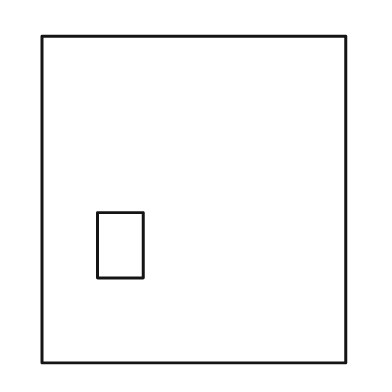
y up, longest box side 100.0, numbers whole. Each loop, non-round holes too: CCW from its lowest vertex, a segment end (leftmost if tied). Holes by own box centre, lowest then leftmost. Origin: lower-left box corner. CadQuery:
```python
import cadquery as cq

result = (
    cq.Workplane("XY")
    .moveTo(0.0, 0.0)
    .lineTo(93.0, 0.0)
    .lineTo(93.0, 100.0)
    .lineTo(0.0, 100.0)
    .close()
    .moveTo(17.0, 26.0)
    .lineTo(31.0, 26.0)
    .lineTo(31.0, 46.0)
    .lineTo(17.0, 46.0)
    .close()
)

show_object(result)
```